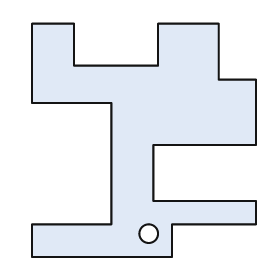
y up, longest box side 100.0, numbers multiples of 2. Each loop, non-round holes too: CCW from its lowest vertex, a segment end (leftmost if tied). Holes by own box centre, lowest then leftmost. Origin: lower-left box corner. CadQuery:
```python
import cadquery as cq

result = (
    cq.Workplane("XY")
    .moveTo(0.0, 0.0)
    .lineTo(60.0, 0.0)
    .lineTo(60.0, 14.0)
    .lineTo(96.0, 14.0)
    .lineTo(96.0, 24.0)
    .lineTo(52.0, 24.0)
    .lineTo(52.0, 48.0)
    .lineTo(96.0, 48.0)
    .lineTo(96.0, 76.0)
    .lineTo(80.0, 76.0)
    .lineTo(80.0, 100.0)
    .lineTo(54.0, 100.0)
    .lineTo(54.0, 82.0)
    .lineTo(18.0, 82.0)
    .lineTo(18.0, 100.0)
    .lineTo(0.0, 100.0)
    .lineTo(0.0, 66.0)
    .lineTo(34.0, 66.0)
    .lineTo(34.0, 14.0)
    .lineTo(0.0, 14.0)
    .close()
    .moveTo(50.0, 10.0)
    .circle(4.0)
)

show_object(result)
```